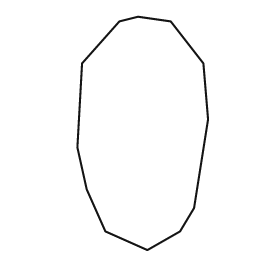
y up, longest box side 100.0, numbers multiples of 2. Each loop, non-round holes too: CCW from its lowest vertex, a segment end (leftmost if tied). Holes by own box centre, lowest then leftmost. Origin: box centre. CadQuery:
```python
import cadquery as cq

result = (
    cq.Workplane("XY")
    .moveTo(2.0, -50.0)
    .lineTo(16.0, -42.0)
    .lineTo(22.0, -32.0)
    .lineTo(28.0, 6.0)
    .lineTo(26.0, 30.0)
    .lineTo(12.0, 48.0)
    .lineTo(-2.0, 50.0)
    .lineTo(-10.0, 48.0)
    .lineTo(-26.0, 30.0)
    .lineTo(-28.0, -6.0)
    .lineTo(-24.0, -24.0)
    .lineTo(-16.0, -42.0)
    .close()
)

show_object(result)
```